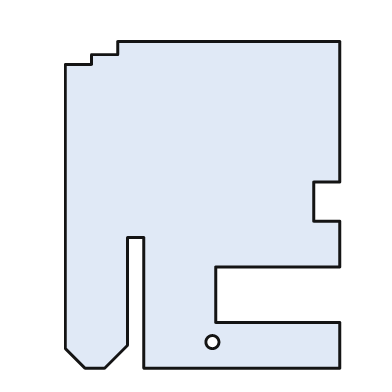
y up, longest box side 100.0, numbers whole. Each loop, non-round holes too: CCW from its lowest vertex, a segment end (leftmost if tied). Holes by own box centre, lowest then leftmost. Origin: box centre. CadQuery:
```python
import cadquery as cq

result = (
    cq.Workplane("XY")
    .moveTo(-36.0, -50.0)
    .lineTo(-30.0, -50.0)
    .lineTo(-23.0, -43.0)
    .lineTo(-23.0, -10.0)
    .lineTo(-18.0, -10.0)
    .lineTo(-18.0, -50.0)
    .lineTo(42.0, -50.0)
    .lineTo(42.0, -36.0)
    .lineTo(4.0, -36.0)
    .lineTo(4.0, -19.0)
    .lineTo(42.0, -19.0)
    .lineTo(42.0, -5.0)
    .lineTo(34.0, -5.0)
    .lineTo(34.0, 7.0)
    .lineTo(42.0, 7.0)
    .lineTo(42.0, 50.0)
    .lineTo(-26.0, 50.0)
    .lineTo(-26.0, 46.0)
    .lineTo(-34.0, 46.0)
    .lineTo(-34.0, 43.0)
    .lineTo(-42.0, 43.0)
    .lineTo(-42.0, -44.0)
    .close()
    .moveTo(3.0, -42.0)
    .circle(2.0)
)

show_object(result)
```